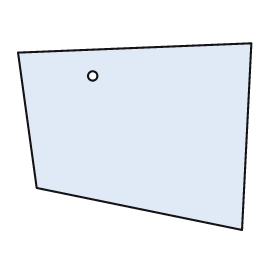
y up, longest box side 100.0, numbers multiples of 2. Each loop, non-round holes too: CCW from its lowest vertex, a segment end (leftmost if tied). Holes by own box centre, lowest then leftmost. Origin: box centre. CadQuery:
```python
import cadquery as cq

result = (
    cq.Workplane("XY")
    .moveTo(46.0, -40.0)
    .lineTo(50.0, 40.0)
    .lineTo(-50.0, 36.0)
    .lineTo(-42.0, -22.0)
    .close()
    .moveTo(-18.0, 26.0)
    .circle(2.0)
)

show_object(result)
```